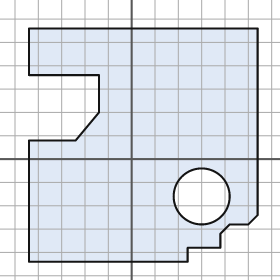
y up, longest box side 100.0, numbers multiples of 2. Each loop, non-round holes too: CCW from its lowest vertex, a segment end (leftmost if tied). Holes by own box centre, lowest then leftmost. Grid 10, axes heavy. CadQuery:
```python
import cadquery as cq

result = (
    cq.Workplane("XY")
    .moveTo(-44.0, -44.0)
    .lineTo(24.0, -44.0)
    .lineTo(24.0, -38.0)
    .lineTo(38.0, -38.0)
    .lineTo(38.0, -32.0)
    .lineTo(42.0, -28.0)
    .lineTo(50.0, -28.0)
    .lineTo(54.0, -24.0)
    .lineTo(54.0, 56.0)
    .lineTo(-44.0, 56.0)
    .lineTo(-44.0, 36.0)
    .lineTo(-14.0, 36.0)
    .lineTo(-14.0, 20.0)
    .lineTo(-24.0, 8.0)
    .lineTo(-44.0, 8.0)
    .close()
    .moveTo(30.0, -16.0)
    .circle(12.0)
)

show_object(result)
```